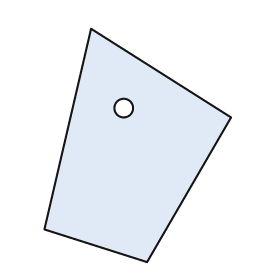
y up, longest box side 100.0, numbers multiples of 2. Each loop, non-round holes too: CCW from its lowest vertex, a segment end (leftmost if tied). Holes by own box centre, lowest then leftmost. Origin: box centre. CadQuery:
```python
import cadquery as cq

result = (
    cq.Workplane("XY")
    .moveTo(4.0, -50.0)
    .lineTo(40.0, 12.0)
    .lineTo(-20.0, 50.0)
    .lineTo(-40.0, -36.0)
    .close()
    .moveTo(-6.0, 16.0)
    .circle(4.0)
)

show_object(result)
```